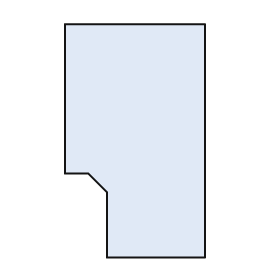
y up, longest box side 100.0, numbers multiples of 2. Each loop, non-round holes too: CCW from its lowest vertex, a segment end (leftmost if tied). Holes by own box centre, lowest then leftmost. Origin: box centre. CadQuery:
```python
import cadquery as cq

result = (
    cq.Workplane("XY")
    .moveTo(-12.0, -50.0)
    .lineTo(30.0, -50.0)
    .lineTo(30.0, 50.0)
    .lineTo(-30.0, 50.0)
    .lineTo(-30.0, -14.0)
    .lineTo(-20.0, -14.0)
    .lineTo(-12.0, -22.0)
    .close()
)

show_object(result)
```